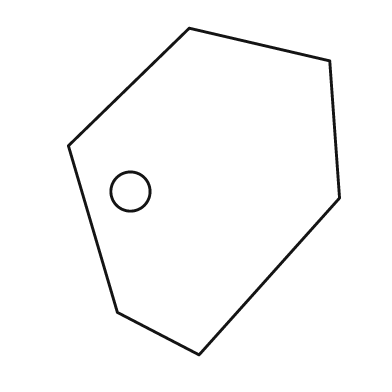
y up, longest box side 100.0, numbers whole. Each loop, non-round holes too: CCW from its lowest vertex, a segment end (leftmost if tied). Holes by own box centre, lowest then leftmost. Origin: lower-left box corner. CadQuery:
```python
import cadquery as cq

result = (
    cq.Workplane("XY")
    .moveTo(40.0, 0.0)
    .lineTo(83.0, 48.0)
    .lineTo(80.0, 90.0)
    .lineTo(37.0, 100.0)
    .lineTo(0.0, 64.0)
    .lineTo(15.0, 13.0)
    .close()
    .moveTo(19.0, 50.0)
    .circle(6.0)
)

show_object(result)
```